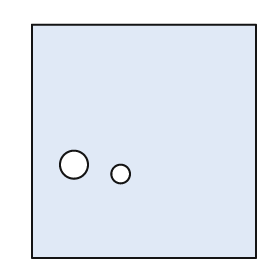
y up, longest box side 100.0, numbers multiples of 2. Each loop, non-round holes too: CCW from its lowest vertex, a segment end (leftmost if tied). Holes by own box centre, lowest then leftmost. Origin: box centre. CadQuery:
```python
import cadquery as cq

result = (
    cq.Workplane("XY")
    .moveTo(-48.0, -50.0)
    .lineTo(48.0, -50.0)
    .lineTo(48.0, 50.0)
    .lineTo(-48.0, 50.0)
    .close()
    .moveTo(-10.0, -14.0)
    .circle(4.0)
    .moveTo(-30.0, -10.0)
    .circle(6.0)
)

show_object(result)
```